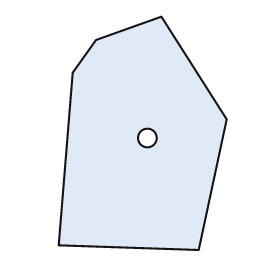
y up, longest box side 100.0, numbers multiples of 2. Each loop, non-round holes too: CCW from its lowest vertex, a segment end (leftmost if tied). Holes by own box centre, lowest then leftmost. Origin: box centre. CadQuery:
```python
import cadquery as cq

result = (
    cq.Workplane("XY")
    .moveTo(24.0, -50.0)
    .lineTo(36.0, 6.0)
    .lineTo(8.0, 50.0)
    .lineTo(-20.0, 40.0)
    .lineTo(-30.0, 26.0)
    .lineTo(-36.0, -48.0)
    .close()
    .moveTo(2.0, -2.0)
    .circle(4.0)
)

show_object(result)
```